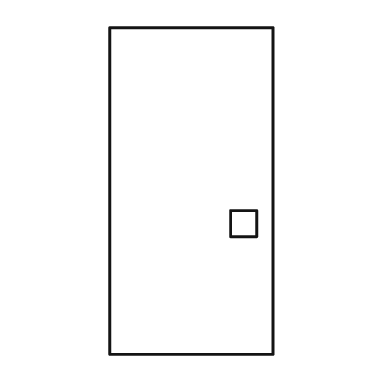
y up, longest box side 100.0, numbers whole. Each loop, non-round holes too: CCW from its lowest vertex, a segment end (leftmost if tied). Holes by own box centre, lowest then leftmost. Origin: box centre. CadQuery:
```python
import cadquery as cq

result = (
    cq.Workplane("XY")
    .moveTo(-25.0, -50.0)
    .lineTo(25.0, -50.0)
    .lineTo(25.0, 50.0)
    .lineTo(-25.0, 50.0)
    .close()
    .moveTo(12.0, -14.0)
    .lineTo(20.0, -14.0)
    .lineTo(20.0, -6.0)
    .lineTo(12.0, -6.0)
    .close()
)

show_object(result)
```